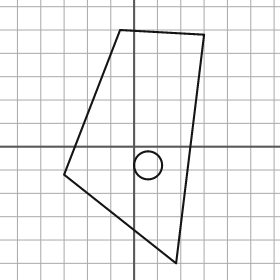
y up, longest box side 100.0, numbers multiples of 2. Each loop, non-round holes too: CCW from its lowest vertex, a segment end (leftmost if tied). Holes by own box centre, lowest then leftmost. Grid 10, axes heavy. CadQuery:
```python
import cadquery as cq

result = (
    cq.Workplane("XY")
    .moveTo(18.0, -50.0)
    .lineTo(30.0, 48.0)
    .lineTo(-6.0, 50.0)
    .lineTo(-30.0, -12.0)
    .close()
    .moveTo(6.0, -8.0)
    .circle(6.0)
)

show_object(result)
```